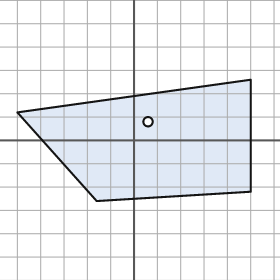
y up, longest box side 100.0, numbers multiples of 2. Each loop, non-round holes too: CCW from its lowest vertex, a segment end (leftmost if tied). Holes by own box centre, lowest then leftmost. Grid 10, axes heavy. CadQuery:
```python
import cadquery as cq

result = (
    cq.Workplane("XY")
    .moveTo(-16.0, -26.0)
    .lineTo(50.0, -22.0)
    .lineTo(50.0, 26.0)
    .lineTo(-50.0, 12.0)
    .close()
    .moveTo(6.0, 8.0)
    .circle(2.0)
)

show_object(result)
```